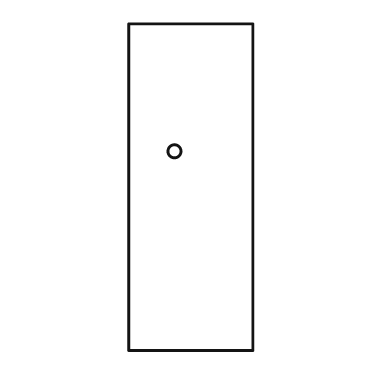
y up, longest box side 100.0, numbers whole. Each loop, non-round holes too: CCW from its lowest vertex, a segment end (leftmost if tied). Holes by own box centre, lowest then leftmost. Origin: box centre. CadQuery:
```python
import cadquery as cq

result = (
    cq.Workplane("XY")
    .moveTo(-19.0, -50.0)
    .lineTo(19.0, -50.0)
    .lineTo(19.0, 50.0)
    .lineTo(-19.0, 50.0)
    .close()
    .moveTo(-5.0, 11.0)
    .circle(2.0)
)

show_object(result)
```